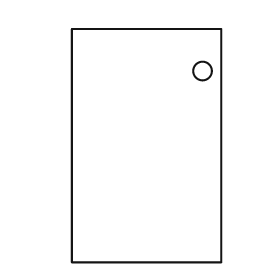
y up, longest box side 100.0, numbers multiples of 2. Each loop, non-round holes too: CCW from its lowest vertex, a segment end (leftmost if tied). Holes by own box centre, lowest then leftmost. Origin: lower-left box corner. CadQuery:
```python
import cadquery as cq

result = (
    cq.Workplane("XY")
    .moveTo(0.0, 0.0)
    .lineTo(64.0, 0.0)
    .lineTo(64.0, 100.0)
    .lineTo(0.0, 100.0)
    .close()
    .moveTo(56.0, 82.0)
    .circle(4.0)
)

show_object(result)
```